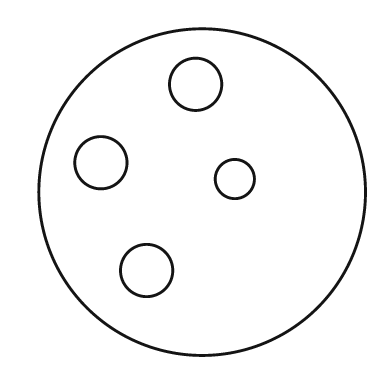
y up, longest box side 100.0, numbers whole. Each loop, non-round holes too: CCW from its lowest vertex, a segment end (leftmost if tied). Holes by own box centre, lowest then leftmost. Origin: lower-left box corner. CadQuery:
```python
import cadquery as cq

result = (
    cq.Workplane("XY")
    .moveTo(50.0, 50.0)
    .circle(50.0)
    .moveTo(33.0, 26.0)
    .circle(8.0)
    .moveTo(60.0, 54.0)
    .circle(6.0)
    .moveTo(19.0, 59.0)
    .circle(8.0)
    .moveTo(48.0, 83.0)
    .circle(8.0)
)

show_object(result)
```